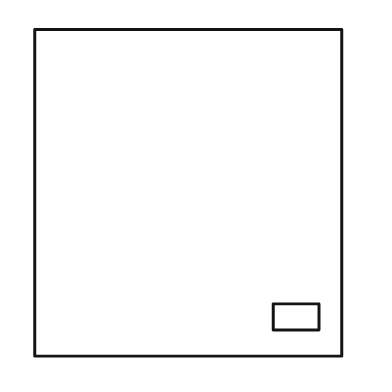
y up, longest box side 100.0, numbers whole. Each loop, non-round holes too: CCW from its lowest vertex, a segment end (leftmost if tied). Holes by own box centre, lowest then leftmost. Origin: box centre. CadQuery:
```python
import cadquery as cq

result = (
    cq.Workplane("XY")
    .moveTo(-47.0, -50.0)
    .lineTo(47.0, -50.0)
    .lineTo(47.0, 50.0)
    .lineTo(-47.0, 50.0)
    .close()
    .moveTo(26.0, -42.0)
    .lineTo(40.0, -42.0)
    .lineTo(40.0, -34.0)
    .lineTo(26.0, -34.0)
    .close()
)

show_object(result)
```